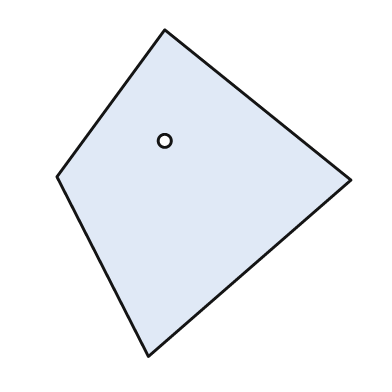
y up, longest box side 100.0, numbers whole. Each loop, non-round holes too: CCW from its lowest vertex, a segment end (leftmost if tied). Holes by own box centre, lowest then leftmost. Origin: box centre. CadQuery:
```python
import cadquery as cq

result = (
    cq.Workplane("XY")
    .moveTo(-17.0, -50.0)
    .lineTo(45.0, 4.0)
    .lineTo(-12.0, 50.0)
    .lineTo(-45.0, 5.0)
    .close()
    .moveTo(-12.0, 16.0)
    .circle(2.0)
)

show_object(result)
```